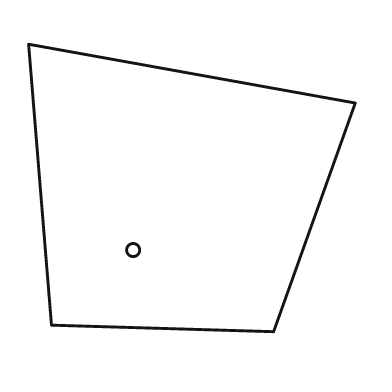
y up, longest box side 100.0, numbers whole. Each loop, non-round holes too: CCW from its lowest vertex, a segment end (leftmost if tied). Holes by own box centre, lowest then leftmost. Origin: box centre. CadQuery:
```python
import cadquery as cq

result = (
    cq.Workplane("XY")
    .moveTo(25.0, -44.0)
    .lineTo(50.0, 26.0)
    .lineTo(-50.0, 44.0)
    .lineTo(-43.0, -42.0)
    .close()
    .moveTo(-18.0, -19.0)
    .circle(2.0)
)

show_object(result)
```